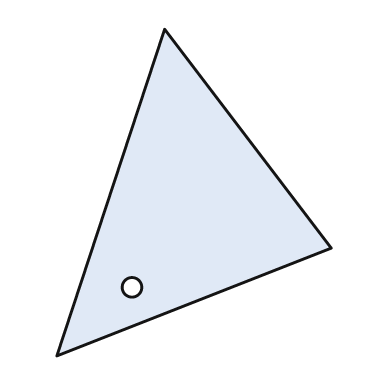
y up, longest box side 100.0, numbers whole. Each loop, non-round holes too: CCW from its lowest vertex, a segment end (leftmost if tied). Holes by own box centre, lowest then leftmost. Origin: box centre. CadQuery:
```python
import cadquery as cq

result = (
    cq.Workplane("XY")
    .moveTo(-42.0, -50.0)
    .lineTo(42.0, -17.0)
    .lineTo(-9.0, 50.0)
    .close()
    .moveTo(-19.0, -29.0)
    .circle(3.0)
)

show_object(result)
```